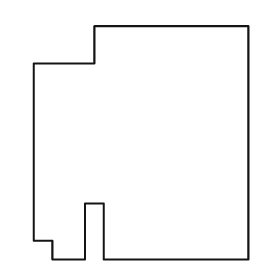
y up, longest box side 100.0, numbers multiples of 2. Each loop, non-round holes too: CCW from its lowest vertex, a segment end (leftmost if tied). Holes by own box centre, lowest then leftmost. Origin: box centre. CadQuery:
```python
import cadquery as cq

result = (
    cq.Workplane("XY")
    .moveTo(-38.0, -50.0)
    .lineTo(-24.0, -50.0)
    .lineTo(-24.0, -26.0)
    .lineTo(-16.0, -26.0)
    .lineTo(-16.0, -50.0)
    .lineTo(46.0, -50.0)
    .lineTo(46.0, 50.0)
    .lineTo(-20.0, 50.0)
    .lineTo(-20.0, 34.0)
    .lineTo(-46.0, 34.0)
    .lineTo(-46.0, -42.0)
    .lineTo(-38.0, -42.0)
    .close()
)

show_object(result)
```